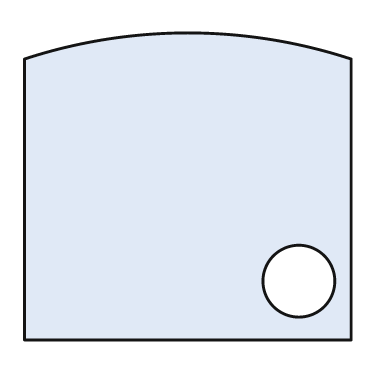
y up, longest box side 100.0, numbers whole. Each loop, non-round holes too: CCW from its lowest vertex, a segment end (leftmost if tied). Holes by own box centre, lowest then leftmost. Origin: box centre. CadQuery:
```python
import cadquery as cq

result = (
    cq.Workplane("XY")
    .moveTo(-50.0, -47.0)
    .lineTo(50.0, -47.0)
    .lineTo(50.0, 39.0)
    .threePointArc((0.0, 47.0), (-50.0, 39.0))
    .close()
    .moveTo(34.0, -29.0)
    .circle(11.0)
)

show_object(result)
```